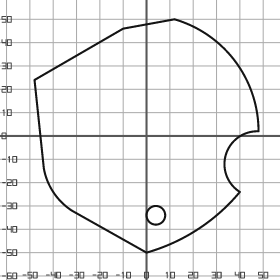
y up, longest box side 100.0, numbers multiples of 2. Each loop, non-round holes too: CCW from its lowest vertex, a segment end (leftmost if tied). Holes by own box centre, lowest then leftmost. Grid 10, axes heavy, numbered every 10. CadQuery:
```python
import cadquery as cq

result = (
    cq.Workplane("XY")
    .moveTo(0.0, -50.0)
    .threePointArc((22.0, -40.0), (40.0, -24.0))
    .threePointArc((34.0, -8.0), (48.0, 2.0))
    .threePointArc((38.0, 32.0), (12.0, 50.0))
    .lineTo(-10.0, 46.0)
    .lineTo(-48.0, 24.0)
    .lineTo(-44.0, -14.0)
    .threePointArc((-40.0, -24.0), (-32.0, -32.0))
    .close()
    .moveTo(4.0, -34.0)
    .circle(4.0)
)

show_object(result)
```